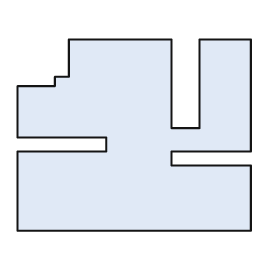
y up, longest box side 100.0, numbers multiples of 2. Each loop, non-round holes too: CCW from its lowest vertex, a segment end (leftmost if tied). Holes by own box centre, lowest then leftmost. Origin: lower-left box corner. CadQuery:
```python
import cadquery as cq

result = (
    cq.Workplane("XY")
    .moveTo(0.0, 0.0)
    .lineTo(100.0, 0.0)
    .lineTo(100.0, 28.0)
    .lineTo(66.0, 28.0)
    .lineTo(66.0, 34.0)
    .lineTo(100.0, 34.0)
    .lineTo(100.0, 82.0)
    .lineTo(78.0, 82.0)
    .lineTo(78.0, 44.0)
    .lineTo(66.0, 44.0)
    .lineTo(66.0, 82.0)
    .lineTo(22.0, 82.0)
    .lineTo(22.0, 66.0)
    .lineTo(16.0, 66.0)
    .lineTo(16.0, 62.0)
    .lineTo(0.0, 62.0)
    .lineTo(0.0, 40.0)
    .lineTo(38.0, 40.0)
    .lineTo(38.0, 34.0)
    .lineTo(0.0, 34.0)
    .close()
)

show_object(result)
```